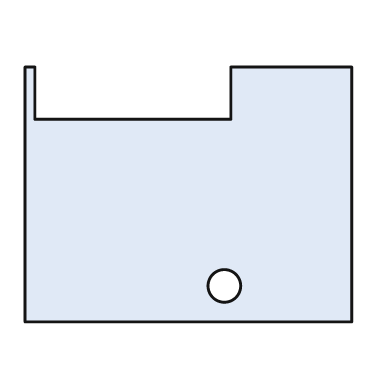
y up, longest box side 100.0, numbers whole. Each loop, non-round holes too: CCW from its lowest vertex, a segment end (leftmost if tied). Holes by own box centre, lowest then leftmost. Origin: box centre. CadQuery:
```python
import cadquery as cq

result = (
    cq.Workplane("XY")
    .moveTo(-50.0, -39.0)
    .lineTo(50.0, -39.0)
    .lineTo(50.0, 39.0)
    .lineTo(13.0, 39.0)
    .lineTo(13.0, 23.0)
    .lineTo(-47.0, 23.0)
    .lineTo(-47.0, 39.0)
    .lineTo(-50.0, 39.0)
    .close()
    .moveTo(11.0, -28.0)
    .circle(5.0)
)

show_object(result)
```